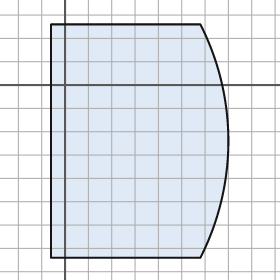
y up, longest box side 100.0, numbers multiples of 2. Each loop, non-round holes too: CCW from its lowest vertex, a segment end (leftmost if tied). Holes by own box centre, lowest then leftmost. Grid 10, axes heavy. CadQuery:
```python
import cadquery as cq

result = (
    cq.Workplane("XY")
    .moveTo(-6.0, -74.0)
    .lineTo(58.0, -74.0)
    .threePointArc((70.0, -24.0), (58.0, 26.0))
    .lineTo(-6.0, 26.0)
    .close()
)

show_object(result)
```